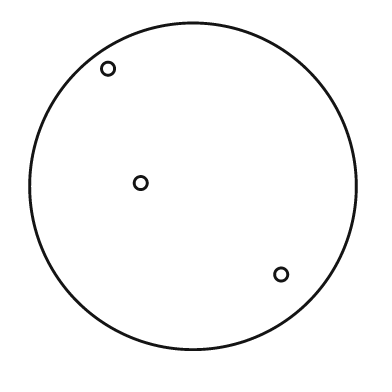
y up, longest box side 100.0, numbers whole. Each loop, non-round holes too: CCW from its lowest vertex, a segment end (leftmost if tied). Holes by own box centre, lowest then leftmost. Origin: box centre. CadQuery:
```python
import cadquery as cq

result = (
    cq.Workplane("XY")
    .moveTo(0.0, 0.0)
    .circle(50.0)
    .moveTo(27.0, -27.0)
    .circle(2.0)
    .moveTo(-16.0, 1.0)
    .circle(2.0)
    .moveTo(-26.0, 36.0)
    .circle(2.0)
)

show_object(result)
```